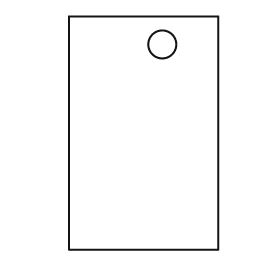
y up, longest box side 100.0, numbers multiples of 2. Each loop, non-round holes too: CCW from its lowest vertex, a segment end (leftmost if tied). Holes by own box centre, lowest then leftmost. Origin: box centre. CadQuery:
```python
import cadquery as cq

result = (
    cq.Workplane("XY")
    .moveTo(-32.0, -50.0)
    .lineTo(32.0, -50.0)
    .lineTo(32.0, 50.0)
    .lineTo(-32.0, 50.0)
    .close()
    .moveTo(8.0, 38.0)
    .circle(6.0)
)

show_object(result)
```